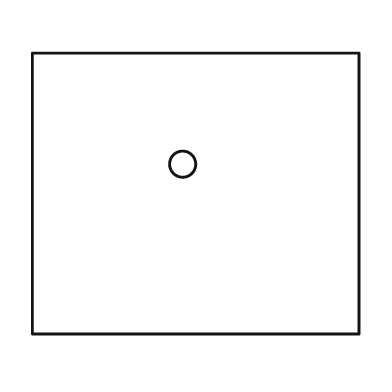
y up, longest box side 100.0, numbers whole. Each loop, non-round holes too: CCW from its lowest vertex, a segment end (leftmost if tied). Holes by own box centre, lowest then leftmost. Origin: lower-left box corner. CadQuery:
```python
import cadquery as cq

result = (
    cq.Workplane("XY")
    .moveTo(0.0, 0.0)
    .lineTo(100.0, 0.0)
    .lineTo(100.0, 86.0)
    .lineTo(0.0, 86.0)
    .close()
    .moveTo(46.0, 52.0)
    .circle(4.0)
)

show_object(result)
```